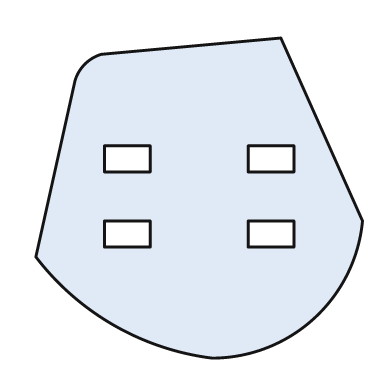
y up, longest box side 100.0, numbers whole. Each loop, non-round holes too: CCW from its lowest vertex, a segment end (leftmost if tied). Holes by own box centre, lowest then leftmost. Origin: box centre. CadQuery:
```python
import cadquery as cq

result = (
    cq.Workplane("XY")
    .moveTo(4.0, -49.0)
    .threePointArc((35.0, -37.0), (50.0, -7.0))
    .lineTo(25.0, 49.0)
    .lineTo(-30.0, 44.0)
    .threePointArc((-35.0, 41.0), (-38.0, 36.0))
    .lineTo(-50.0, -18.0)
    .threePointArc((-26.0, -39.0), (4.0, -49.0))
    .close()
    .moveTo(-29.0, -15.0)
    .lineTo(-15.0, -15.0)
    .lineTo(-15.0, -7.0)
    .lineTo(-29.0, -7.0)
    .close()
    .moveTo(15.0, -15.0)
    .lineTo(29.0, -15.0)
    .lineTo(29.0, -7.0)
    .lineTo(15.0, -7.0)
    .close()
    .moveTo(-29.0, 8.0)
    .lineTo(-15.0, 8.0)
    .lineTo(-15.0, 16.0)
    .lineTo(-29.0, 16.0)
    .close()
    .moveTo(15.0, 8.0)
    .lineTo(29.0, 8.0)
    .lineTo(29.0, 16.0)
    .lineTo(15.0, 16.0)
    .close()
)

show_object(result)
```